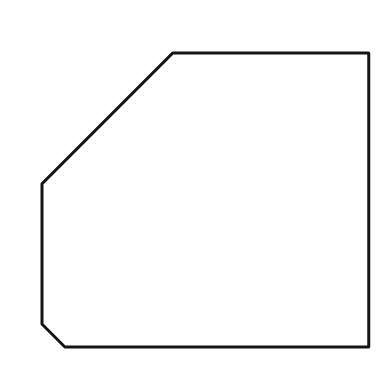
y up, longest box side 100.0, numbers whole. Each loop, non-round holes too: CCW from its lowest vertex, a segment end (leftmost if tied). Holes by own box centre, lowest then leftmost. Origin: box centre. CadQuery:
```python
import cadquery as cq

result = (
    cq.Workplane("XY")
    .moveTo(-43.0, -45.0)
    .lineTo(50.0, -45.0)
    .lineTo(50.0, 45.0)
    .lineTo(-10.0, 45.0)
    .lineTo(-50.0, 5.0)
    .lineTo(-50.0, -38.0)
    .close()
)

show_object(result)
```